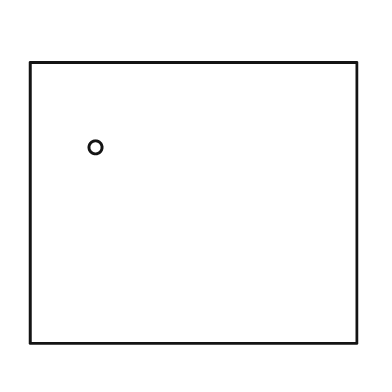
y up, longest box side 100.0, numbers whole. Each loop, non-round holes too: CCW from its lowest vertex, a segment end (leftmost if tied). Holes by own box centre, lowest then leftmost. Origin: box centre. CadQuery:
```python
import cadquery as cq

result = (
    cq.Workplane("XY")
    .moveTo(-50.0, -43.0)
    .lineTo(50.0, -43.0)
    .lineTo(50.0, 43.0)
    .lineTo(-50.0, 43.0)
    .close()
    .moveTo(-30.0, 17.0)
    .circle(2.0)
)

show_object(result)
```